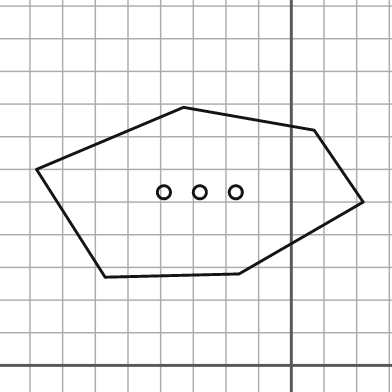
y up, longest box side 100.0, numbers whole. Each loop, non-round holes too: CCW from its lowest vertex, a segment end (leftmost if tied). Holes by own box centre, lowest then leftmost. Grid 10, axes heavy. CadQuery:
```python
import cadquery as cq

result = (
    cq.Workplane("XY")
    .moveTo(-57.0, 27.0)
    .lineTo(-16.0, 28.0)
    .lineTo(22.0, 50.0)
    .lineTo(7.0, 72.0)
    .lineTo(-33.0, 79.0)
    .lineTo(-78.0, 60.0)
    .close()
    .moveTo(-39.0, 53.0)
    .circle(2.0)
    .moveTo(-28.0, 53.0)
    .circle(2.0)
    .moveTo(-17.0, 53.0)
    .circle(2.0)
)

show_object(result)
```